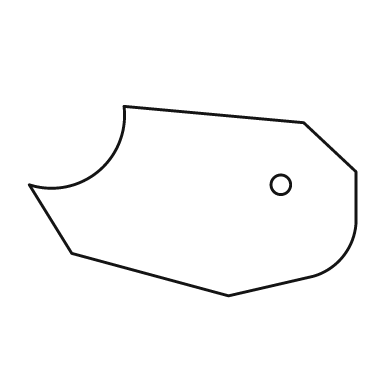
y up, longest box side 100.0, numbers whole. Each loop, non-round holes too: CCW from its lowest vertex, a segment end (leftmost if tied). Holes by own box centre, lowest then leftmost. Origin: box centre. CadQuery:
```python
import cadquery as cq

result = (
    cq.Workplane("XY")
    .moveTo(11.0, -29.0)
    .lineTo(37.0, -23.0)
    .threePointArc((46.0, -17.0), (50.0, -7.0))
    .lineTo(50.0, 9.0)
    .lineTo(34.0, 24.0)
    .lineTo(-21.0, 29.0)
    .threePointArc((-29.0, 9.0), (-50.0, 5.0))
    .lineTo(-37.0, -16.0)
    .close()
    .moveTo(27.0, 5.0)
    .circle(3.0)
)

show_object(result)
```